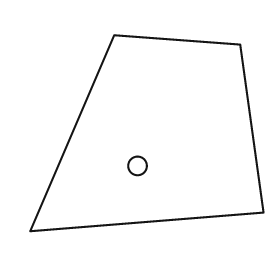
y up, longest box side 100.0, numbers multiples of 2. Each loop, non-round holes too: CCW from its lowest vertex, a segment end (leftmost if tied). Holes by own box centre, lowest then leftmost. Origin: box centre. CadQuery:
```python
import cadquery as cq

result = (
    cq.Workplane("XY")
    .moveTo(-50.0, -42.0)
    .lineTo(50.0, -34.0)
    .lineTo(40.0, 38.0)
    .lineTo(-14.0, 42.0)
    .close()
    .moveTo(-4.0, -14.0)
    .circle(4.0)
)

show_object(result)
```